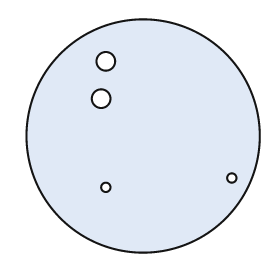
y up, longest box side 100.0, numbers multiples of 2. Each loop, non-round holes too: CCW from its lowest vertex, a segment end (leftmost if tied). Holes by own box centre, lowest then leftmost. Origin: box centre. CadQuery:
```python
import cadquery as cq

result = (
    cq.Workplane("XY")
    .moveTo(0.0, 0.0)
    .circle(50.0)
    .moveTo(-16.0, -22.0)
    .circle(2.0)
    .moveTo(38.0, -18.0)
    .circle(2.0)
    .moveTo(-18.0, 16.0)
    .circle(4.0)
    .moveTo(-16.0, 32.0)
    .circle(4.0)
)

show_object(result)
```